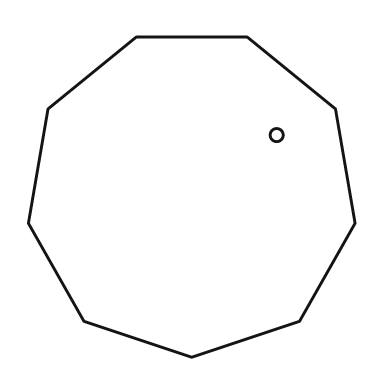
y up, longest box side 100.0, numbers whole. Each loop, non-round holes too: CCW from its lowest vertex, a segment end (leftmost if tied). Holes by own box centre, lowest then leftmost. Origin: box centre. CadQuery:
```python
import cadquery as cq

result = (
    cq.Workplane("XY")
    .moveTo(0.0, -49.0)
    .lineTo(33.0, -38.0)
    .lineTo(50.0, -8.0)
    .lineTo(44.0, 27.0)
    .lineTo(17.0, 49.0)
    .lineTo(-17.0, 49.0)
    .lineTo(-44.0, 27.0)
    .lineTo(-50.0, -8.0)
    .lineTo(-33.0, -38.0)
    .close()
    .moveTo(26.0, 19.0)
    .circle(2.0)
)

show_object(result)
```